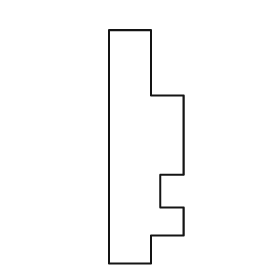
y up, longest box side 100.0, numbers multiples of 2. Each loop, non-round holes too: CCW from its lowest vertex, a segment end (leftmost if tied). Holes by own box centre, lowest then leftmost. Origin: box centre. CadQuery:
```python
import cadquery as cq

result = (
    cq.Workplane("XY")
    .moveTo(-16.0, -50.0)
    .lineTo(2.0, -50.0)
    .lineTo(2.0, -38.0)
    .lineTo(16.0, -38.0)
    .lineTo(16.0, -26.0)
    .lineTo(6.0, -26.0)
    .lineTo(6.0, -12.0)
    .lineTo(16.0, -12.0)
    .lineTo(16.0, 22.0)
    .lineTo(2.0, 22.0)
    .lineTo(2.0, 50.0)
    .lineTo(-16.0, 50.0)
    .close()
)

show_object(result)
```